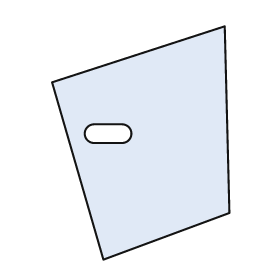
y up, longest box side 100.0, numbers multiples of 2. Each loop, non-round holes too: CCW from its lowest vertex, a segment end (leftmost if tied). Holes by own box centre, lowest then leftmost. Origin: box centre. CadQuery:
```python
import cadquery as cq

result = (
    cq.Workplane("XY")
    .moveTo(-16.0, -50.0)
    .lineTo(38.0, -30.0)
    .lineTo(36.0, 50.0)
    .lineTo(-38.0, 26.0)
    .close()
    .moveTo(-20.0, 0.0)
    .lineTo(-8.0, 0.0)
    .threePointArc((-4.0, 4.0), (-8.0, 8.0))
    .lineTo(-20.0, 8.0)
    .threePointArc((-24.0, 4.0), (-20.0, 0.0))
    .close()
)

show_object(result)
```